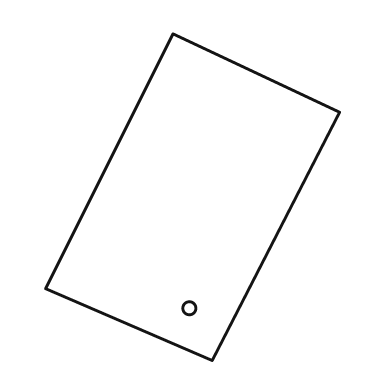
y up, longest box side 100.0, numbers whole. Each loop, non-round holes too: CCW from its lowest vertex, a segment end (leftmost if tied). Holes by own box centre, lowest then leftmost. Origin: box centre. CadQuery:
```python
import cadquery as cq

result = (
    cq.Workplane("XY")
    .moveTo(6.0, -50.0)
    .lineTo(45.0, 26.0)
    .lineTo(-6.0, 50.0)
    .lineTo(-45.0, -28.0)
    .close()
    .moveTo(-1.0, -34.0)
    .circle(2.0)
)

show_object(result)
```